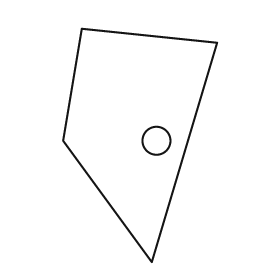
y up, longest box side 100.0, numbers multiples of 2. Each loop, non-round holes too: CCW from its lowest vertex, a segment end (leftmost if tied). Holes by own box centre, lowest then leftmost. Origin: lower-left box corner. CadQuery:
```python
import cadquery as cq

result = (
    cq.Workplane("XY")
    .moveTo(38.0, 0.0)
    .lineTo(66.0, 94.0)
    .lineTo(8.0, 100.0)
    .lineTo(0.0, 52.0)
    .close()
    .moveTo(40.0, 52.0)
    .circle(6.0)
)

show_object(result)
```